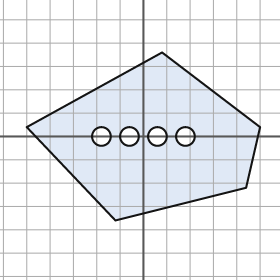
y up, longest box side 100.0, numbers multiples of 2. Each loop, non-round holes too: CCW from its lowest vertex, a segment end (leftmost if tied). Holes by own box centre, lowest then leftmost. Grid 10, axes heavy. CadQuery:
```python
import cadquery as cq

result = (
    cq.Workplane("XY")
    .moveTo(-12.0, -36.0)
    .lineTo(44.0, -22.0)
    .lineTo(50.0, 4.0)
    .lineTo(8.0, 36.0)
    .lineTo(-50.0, 4.0)
    .close()
    .moveTo(-18.0, 0.0)
    .circle(4.0)
    .moveTo(-6.0, 0.0)
    .circle(4.0)
    .moveTo(6.0, 0.0)
    .circle(4.0)
    .moveTo(18.0, 0.0)
    .circle(4.0)
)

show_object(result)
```